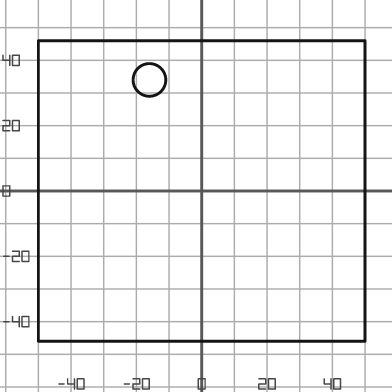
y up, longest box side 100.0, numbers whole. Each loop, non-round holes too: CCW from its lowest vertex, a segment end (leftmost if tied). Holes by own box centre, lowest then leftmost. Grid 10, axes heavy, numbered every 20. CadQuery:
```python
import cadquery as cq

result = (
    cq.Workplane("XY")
    .moveTo(-50.0, -46.0)
    .lineTo(50.0, -46.0)
    .lineTo(50.0, 46.0)
    .lineTo(-50.0, 46.0)
    .close()
    .moveTo(-16.0, 34.0)
    .circle(5.0)
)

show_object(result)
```